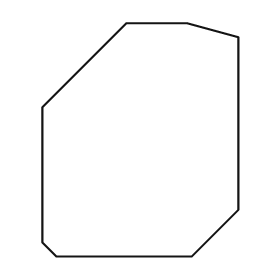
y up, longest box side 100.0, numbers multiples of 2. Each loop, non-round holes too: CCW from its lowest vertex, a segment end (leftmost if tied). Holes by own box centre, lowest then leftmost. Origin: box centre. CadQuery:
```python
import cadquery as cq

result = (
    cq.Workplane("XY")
    .moveTo(-36.0, -50.0)
    .lineTo(22.0, -50.0)
    .lineTo(42.0, -30.0)
    .lineTo(42.0, 44.0)
    .lineTo(20.0, 50.0)
    .lineTo(-6.0, 50.0)
    .lineTo(-42.0, 14.0)
    .lineTo(-42.0, -44.0)
    .close()
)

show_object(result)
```